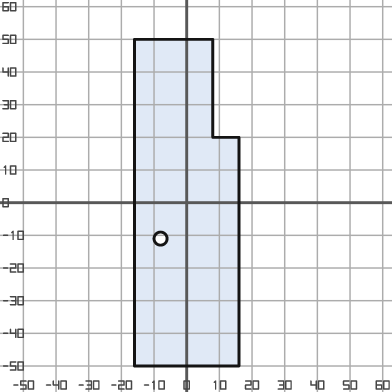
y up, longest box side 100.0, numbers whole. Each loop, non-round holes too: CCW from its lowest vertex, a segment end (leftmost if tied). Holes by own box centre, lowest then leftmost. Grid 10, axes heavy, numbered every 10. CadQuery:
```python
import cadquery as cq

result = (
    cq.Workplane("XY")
    .moveTo(-16.0, -50.0)
    .lineTo(16.0, -50.0)
    .lineTo(16.0, 20.0)
    .lineTo(8.0, 20.0)
    .lineTo(8.0, 50.0)
    .lineTo(-16.0, 50.0)
    .close()
    .moveTo(-8.0, -11.0)
    .circle(2.0)
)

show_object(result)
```